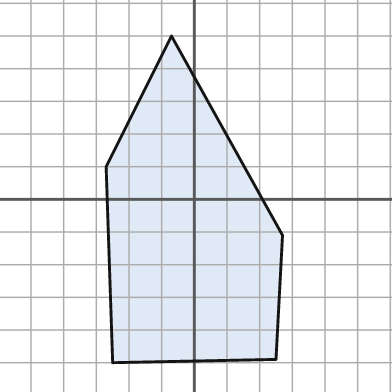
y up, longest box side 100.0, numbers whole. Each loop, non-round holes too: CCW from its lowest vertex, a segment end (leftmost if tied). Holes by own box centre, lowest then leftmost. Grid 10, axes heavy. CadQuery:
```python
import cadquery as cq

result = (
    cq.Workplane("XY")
    .moveTo(-25.0, -50.0)
    .lineTo(25.0, -49.0)
    .lineTo(27.0, -11.0)
    .lineTo(-7.0, 50.0)
    .lineTo(-27.0, 10.0)
    .close()
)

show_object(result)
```